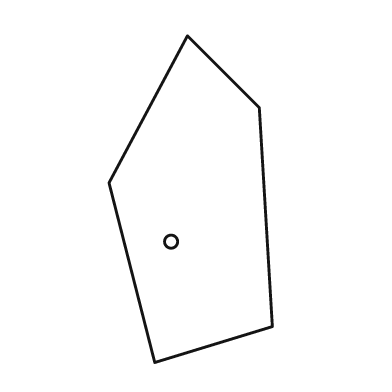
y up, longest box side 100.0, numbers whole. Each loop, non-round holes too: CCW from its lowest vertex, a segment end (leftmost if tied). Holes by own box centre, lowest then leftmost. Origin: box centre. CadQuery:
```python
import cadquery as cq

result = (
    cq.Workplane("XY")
    .moveTo(-11.0, -50.0)
    .lineTo(25.0, -39.0)
    .lineTo(21.0, 28.0)
    .lineTo(-1.0, 50.0)
    .lineTo(-25.0, 5.0)
    .close()
    .moveTo(-6.0, -13.0)
    .circle(2.0)
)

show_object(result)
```